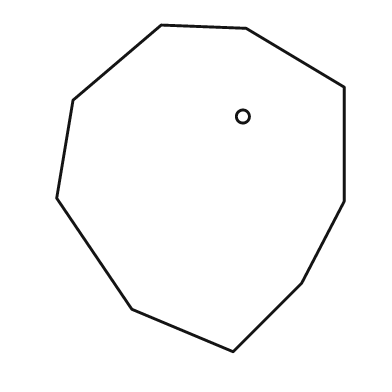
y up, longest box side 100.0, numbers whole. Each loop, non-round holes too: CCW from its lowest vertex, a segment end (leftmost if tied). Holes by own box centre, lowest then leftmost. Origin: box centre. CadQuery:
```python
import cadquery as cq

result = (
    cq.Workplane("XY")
    .moveTo(10.0, -50.0)
    .lineTo(31.0, -29.0)
    .lineTo(44.0, -4.0)
    .lineTo(44.0, 31.0)
    .lineTo(14.0, 49.0)
    .lineTo(-12.0, 50.0)
    .lineTo(-39.0, 27.0)
    .lineTo(-44.0, -3.0)
    .lineTo(-21.0, -37.0)
    .close()
    .moveTo(13.0, 22.0)
    .circle(2.0)
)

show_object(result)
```